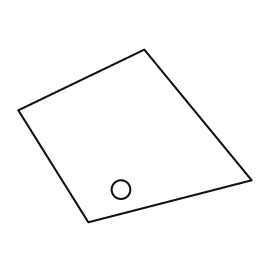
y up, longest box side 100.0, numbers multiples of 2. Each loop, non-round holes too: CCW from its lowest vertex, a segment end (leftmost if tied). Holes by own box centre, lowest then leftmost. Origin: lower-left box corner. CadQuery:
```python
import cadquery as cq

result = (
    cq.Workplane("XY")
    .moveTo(30.0, 0.0)
    .lineTo(100.0, 18.0)
    .lineTo(54.0, 74.0)
    .lineTo(0.0, 48.0)
    .close()
    .moveTo(44.0, 14.0)
    .circle(4.0)
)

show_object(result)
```